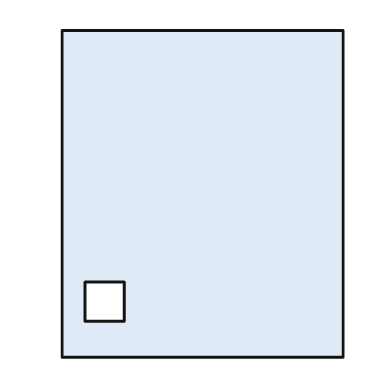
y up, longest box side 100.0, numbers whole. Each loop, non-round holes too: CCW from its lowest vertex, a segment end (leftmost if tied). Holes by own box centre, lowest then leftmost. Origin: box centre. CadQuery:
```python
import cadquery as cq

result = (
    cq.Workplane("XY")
    .moveTo(-43.0, -50.0)
    .lineTo(43.0, -50.0)
    .lineTo(43.0, 50.0)
    .lineTo(-43.0, 50.0)
    .close()
    .moveTo(-36.0, -39.0)
    .lineTo(-24.0, -39.0)
    .lineTo(-24.0, -27.0)
    .lineTo(-36.0, -27.0)
    .close()
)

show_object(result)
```